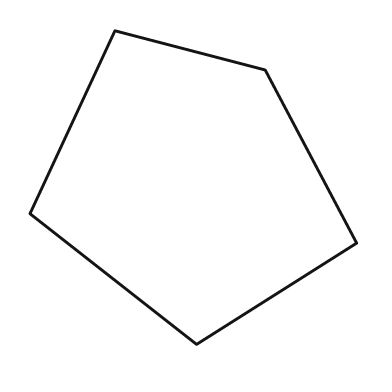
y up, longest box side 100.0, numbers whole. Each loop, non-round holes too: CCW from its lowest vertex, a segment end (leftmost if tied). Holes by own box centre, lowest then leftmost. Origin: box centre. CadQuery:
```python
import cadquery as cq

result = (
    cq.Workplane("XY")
    .moveTo(1.0, -48.0)
    .lineTo(50.0, -17.0)
    .lineTo(22.0, 36.0)
    .lineTo(-24.0, 48.0)
    .lineTo(-50.0, -8.0)
    .close()
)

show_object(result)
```